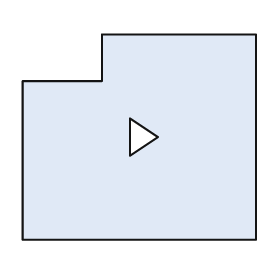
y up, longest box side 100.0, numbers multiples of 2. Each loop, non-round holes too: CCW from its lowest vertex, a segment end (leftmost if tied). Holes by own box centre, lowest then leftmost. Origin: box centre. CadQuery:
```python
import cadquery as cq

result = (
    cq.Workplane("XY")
    .moveTo(-50.0, -44.0)
    .lineTo(50.0, -44.0)
    .lineTo(50.0, 44.0)
    .lineTo(-16.0, 44.0)
    .lineTo(-16.0, 24.0)
    .lineTo(-50.0, 24.0)
    .close()
    .moveTo(-4.0, -8.0)
    .lineTo(8.0, 0.0)
    .lineTo(-4.0, 8.0)
    .close()
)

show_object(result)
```